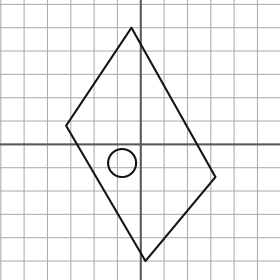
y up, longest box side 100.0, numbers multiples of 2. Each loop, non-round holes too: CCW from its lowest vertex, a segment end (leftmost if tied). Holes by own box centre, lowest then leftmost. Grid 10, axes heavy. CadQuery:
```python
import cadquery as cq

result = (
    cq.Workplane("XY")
    .moveTo(2.0, -50.0)
    .lineTo(32.0, -14.0)
    .lineTo(-4.0, 50.0)
    .lineTo(-32.0, 8.0)
    .close()
    .moveTo(-8.0, -8.0)
    .circle(6.0)
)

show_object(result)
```